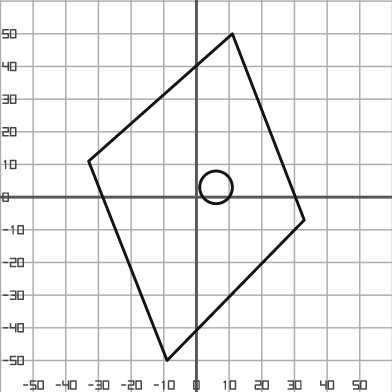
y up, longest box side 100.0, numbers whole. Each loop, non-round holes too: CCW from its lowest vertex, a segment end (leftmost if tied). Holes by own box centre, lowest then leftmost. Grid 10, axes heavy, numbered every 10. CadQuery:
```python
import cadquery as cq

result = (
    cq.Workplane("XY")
    .moveTo(-9.0, -50.0)
    .lineTo(33.0, -7.0)
    .lineTo(11.0, 50.0)
    .lineTo(-33.0, 11.0)
    .close()
    .moveTo(6.0, 3.0)
    .circle(5.0)
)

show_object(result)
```